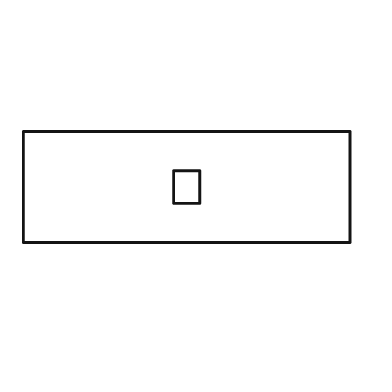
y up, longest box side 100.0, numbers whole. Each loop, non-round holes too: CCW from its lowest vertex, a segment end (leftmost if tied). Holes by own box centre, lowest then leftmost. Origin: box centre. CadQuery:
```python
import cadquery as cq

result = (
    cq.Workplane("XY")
    .moveTo(-50.0, -17.0)
    .lineTo(50.0, -17.0)
    .lineTo(50.0, 17.0)
    .lineTo(-50.0, 17.0)
    .close()
    .moveTo(-4.0, -5.0)
    .lineTo(4.0, -5.0)
    .lineTo(4.0, 5.0)
    .lineTo(-4.0, 5.0)
    .close()
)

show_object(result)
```